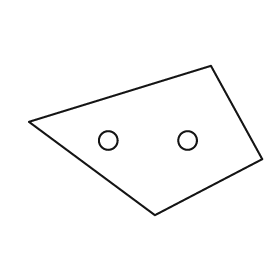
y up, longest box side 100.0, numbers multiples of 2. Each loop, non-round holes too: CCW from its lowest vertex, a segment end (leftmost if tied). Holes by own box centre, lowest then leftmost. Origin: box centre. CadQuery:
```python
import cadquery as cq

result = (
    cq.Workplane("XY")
    .moveTo(4.0, -32.0)
    .lineTo(50.0, -8.0)
    .lineTo(28.0, 32.0)
    .lineTo(-50.0, 8.0)
    .close()
    .moveTo(-16.0, 0.0)
    .circle(4.0)
    .moveTo(18.0, 0.0)
    .circle(4.0)
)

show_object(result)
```